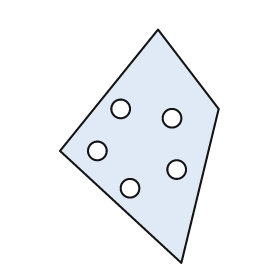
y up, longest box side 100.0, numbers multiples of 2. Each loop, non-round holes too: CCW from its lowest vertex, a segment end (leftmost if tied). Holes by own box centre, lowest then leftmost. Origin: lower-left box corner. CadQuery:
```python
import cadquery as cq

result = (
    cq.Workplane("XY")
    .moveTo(52.0, 0.0)
    .lineTo(68.0, 66.0)
    .lineTo(42.0, 100.0)
    .lineTo(0.0, 48.0)
    .close()
    .moveTo(30.0, 32.0)
    .circle(4.0)
    .moveTo(50.0, 40.0)
    .circle(4.0)
    .moveTo(16.0, 48.0)
    .circle(4.0)
    .moveTo(48.0, 62.0)
    .circle(4.0)
    .moveTo(26.0, 66.0)
    .circle(4.0)
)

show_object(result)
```